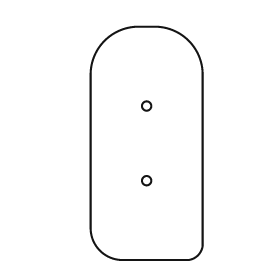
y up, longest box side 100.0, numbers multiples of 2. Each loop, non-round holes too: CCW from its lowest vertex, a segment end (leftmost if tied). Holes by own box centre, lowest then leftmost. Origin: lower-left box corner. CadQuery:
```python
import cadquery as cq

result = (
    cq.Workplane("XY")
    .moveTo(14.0, 0.0)
    .lineTo(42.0, 0.0)
    .threePointArc((46.0, 2.0), (48.0, 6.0))
    .lineTo(48.0, 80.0)
    .threePointArc((42.0, 94.0), (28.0, 100.0))
    .lineTo(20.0, 100.0)
    .threePointArc((6.0, 94.0), (0.0, 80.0))
    .lineTo(0.0, 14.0)
    .threePointArc((4.0, 4.0), (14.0, 0.0))
    .close()
    .moveTo(24.0, 34.0)
    .circle(2.0)
    .moveTo(24.0, 66.0)
    .circle(2.0)
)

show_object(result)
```